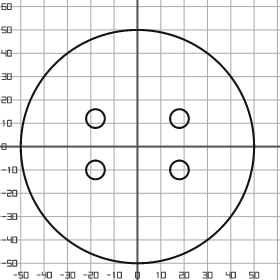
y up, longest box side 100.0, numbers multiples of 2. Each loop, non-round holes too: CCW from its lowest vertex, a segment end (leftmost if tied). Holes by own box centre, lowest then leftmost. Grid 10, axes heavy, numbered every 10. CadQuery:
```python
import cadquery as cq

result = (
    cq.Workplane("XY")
    .moveTo(0.0, 0.0)
    .circle(50.0)
    .moveTo(-18.0, -10.0)
    .circle(4.0)
    .moveTo(18.0, -10.0)
    .circle(4.0)
    .moveTo(-18.0, 12.0)
    .circle(4.0)
    .moveTo(18.0, 12.0)
    .circle(4.0)
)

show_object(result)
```